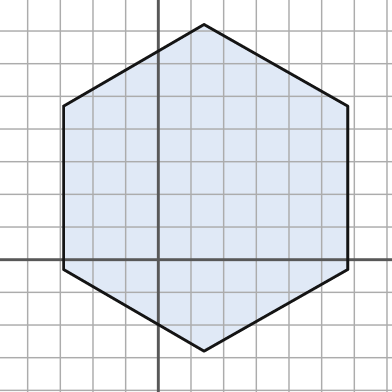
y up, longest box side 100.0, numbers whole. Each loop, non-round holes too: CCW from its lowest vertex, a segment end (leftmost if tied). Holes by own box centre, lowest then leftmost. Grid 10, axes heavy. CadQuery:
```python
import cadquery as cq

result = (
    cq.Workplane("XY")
    .moveTo(14.0, -28.0)
    .lineTo(58.0, -3.0)
    .lineTo(58.0, 47.0)
    .lineTo(14.0, 72.0)
    .lineTo(-29.0, 47.0)
    .lineTo(-29.0, -3.0)
    .close()
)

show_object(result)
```